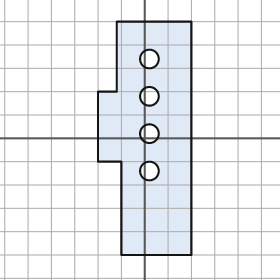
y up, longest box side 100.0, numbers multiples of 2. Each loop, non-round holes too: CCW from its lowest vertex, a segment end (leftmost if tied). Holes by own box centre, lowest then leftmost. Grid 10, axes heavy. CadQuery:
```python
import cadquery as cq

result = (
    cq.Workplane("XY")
    .moveTo(-10.0, -50.0)
    .lineTo(20.0, -50.0)
    .lineTo(20.0, 50.0)
    .lineTo(-12.0, 50.0)
    .lineTo(-12.0, 20.0)
    .lineTo(-20.0, 20.0)
    .lineTo(-20.0, -10.0)
    .lineTo(-10.0, -10.0)
    .close()
    .moveTo(2.0, -14.0)
    .circle(4.0)
    .moveTo(2.0, 2.0)
    .circle(4.0)
    .moveTo(2.0, 18.0)
    .circle(4.0)
    .moveTo(2.0, 34.0)
    .circle(4.0)
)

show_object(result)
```